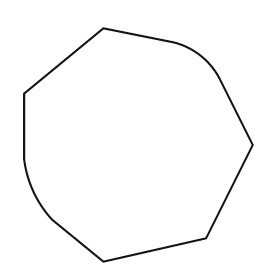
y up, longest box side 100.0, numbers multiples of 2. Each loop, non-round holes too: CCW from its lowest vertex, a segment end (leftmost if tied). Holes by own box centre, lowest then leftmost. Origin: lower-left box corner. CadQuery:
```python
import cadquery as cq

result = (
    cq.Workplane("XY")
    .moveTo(34.0, 0.0)
    .lineTo(78.0, 10.0)
    .lineTo(98.0, 50.0)
    .lineTo(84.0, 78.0)
    .threePointArc((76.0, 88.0), (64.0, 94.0))
    .lineTo(34.0, 100.0)
    .lineTo(0.0, 72.0)
    .lineTo(0.0, 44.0)
    .threePointArc((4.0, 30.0), (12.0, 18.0))
    .close()
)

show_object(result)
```